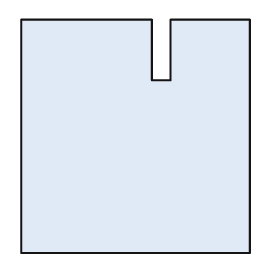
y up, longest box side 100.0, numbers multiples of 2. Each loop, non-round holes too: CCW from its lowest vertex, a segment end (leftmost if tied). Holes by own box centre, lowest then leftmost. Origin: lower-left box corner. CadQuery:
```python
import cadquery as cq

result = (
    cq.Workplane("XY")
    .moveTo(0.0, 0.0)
    .lineTo(98.0, 0.0)
    .lineTo(98.0, 100.0)
    .lineTo(64.0, 100.0)
    .lineTo(64.0, 74.0)
    .lineTo(56.0, 74.0)
    .lineTo(56.0, 100.0)
    .lineTo(0.0, 100.0)
    .close()
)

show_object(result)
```